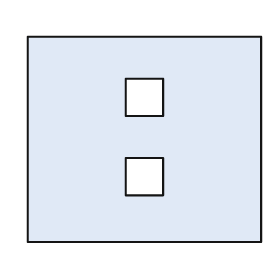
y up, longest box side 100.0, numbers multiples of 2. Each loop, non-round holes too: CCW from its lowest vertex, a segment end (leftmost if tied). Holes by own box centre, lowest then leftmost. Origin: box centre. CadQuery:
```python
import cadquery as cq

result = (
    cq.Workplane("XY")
    .moveTo(-50.0, -44.0)
    .lineTo(50.0, -44.0)
    .lineTo(50.0, 44.0)
    .lineTo(-50.0, 44.0)
    .close()
    .moveTo(-8.0, -24.0)
    .lineTo(8.0, -24.0)
    .lineTo(8.0, -8.0)
    .lineTo(-8.0, -8.0)
    .close()
    .moveTo(-8.0, 10.0)
    .lineTo(8.0, 10.0)
    .lineTo(8.0, 26.0)
    .lineTo(-8.0, 26.0)
    .close()
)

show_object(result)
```